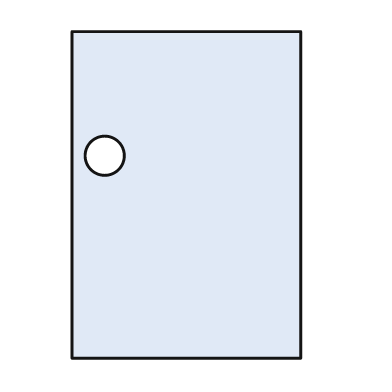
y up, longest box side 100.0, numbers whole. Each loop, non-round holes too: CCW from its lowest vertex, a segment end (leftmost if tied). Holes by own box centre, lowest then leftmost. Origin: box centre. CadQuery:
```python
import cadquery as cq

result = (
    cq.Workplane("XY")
    .moveTo(-35.0, -50.0)
    .lineTo(35.0, -50.0)
    .lineTo(35.0, 50.0)
    .lineTo(-35.0, 50.0)
    .close()
    .moveTo(-25.0, 12.0)
    .circle(6.0)
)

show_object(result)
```